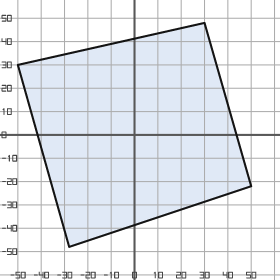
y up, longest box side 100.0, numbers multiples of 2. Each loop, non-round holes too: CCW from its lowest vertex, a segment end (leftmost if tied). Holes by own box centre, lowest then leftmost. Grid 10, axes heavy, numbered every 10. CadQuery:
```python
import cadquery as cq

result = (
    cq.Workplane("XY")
    .moveTo(-28.0, -48.0)
    .lineTo(50.0, -22.0)
    .lineTo(30.0, 48.0)
    .lineTo(-50.0, 30.0)
    .close()
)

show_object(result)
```